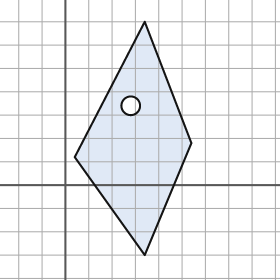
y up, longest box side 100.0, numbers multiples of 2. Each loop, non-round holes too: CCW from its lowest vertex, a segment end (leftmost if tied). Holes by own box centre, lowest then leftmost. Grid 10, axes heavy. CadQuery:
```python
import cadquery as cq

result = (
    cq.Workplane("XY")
    .moveTo(34.0, -30.0)
    .lineTo(54.0, 18.0)
    .lineTo(34.0, 70.0)
    .lineTo(4.0, 12.0)
    .close()
    .moveTo(28.0, 34.0)
    .circle(4.0)
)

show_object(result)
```